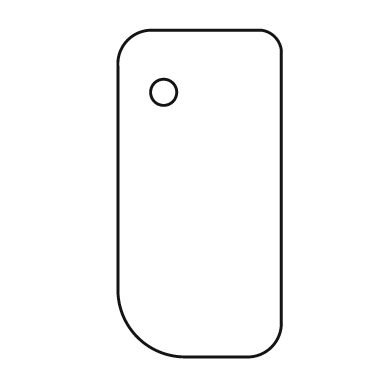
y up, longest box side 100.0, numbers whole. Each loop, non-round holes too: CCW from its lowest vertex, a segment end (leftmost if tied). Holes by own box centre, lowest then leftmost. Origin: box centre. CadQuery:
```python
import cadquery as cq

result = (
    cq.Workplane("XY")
    .moveTo(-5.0, -50.0)
    .lineTo(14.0, -50.0)
    .threePointArc((22.0, -47.0), (25.0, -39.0))
    .lineTo(25.0, 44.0)
    .threePointArc((23.0, 48.0), (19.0, 50.0))
    .lineTo(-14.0, 50.0)
    .threePointArc((-22.0, 47.0), (-25.0, 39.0))
    .lineTo(-25.0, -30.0)
    .threePointArc((-19.0, -44.0), (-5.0, -50.0))
    .close()
    .moveTo(-11.0, 31.0)
    .circle(4.0)
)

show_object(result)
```